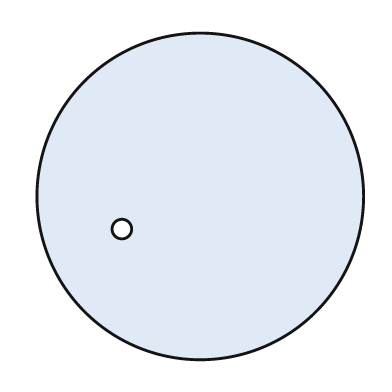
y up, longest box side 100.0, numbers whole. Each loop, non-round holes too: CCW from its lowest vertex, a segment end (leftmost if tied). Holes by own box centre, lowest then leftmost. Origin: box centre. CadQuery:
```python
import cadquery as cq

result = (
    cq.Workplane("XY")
    .moveTo(0.0, 0.0)
    .circle(50.0)
    .moveTo(-24.0, -10.0)
    .circle(3.0)
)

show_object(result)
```